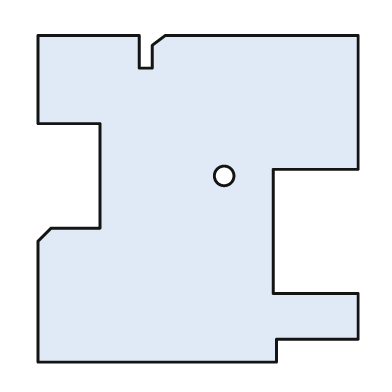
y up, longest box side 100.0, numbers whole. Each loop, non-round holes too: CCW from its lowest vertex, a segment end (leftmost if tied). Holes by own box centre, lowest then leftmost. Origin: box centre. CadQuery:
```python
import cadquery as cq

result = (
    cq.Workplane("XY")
    .moveTo(-49.0, -50.0)
    .lineTo(24.0, -50.0)
    .lineTo(24.0, -43.0)
    .lineTo(49.0, -43.0)
    .lineTo(49.0, -29.0)
    .lineTo(23.0, -29.0)
    .lineTo(23.0, 9.0)
    .lineTo(49.0, 9.0)
    .lineTo(49.0, 50.0)
    .lineTo(-10.0, 50.0)
    .lineTo(-14.0, 47.0)
    .lineTo(-14.0, 40.0)
    .lineTo(-18.0, 40.0)
    .lineTo(-18.0, 50.0)
    .lineTo(-49.0, 50.0)
    .lineTo(-49.0, 23.0)
    .lineTo(-30.0, 23.0)
    .lineTo(-30.0, -9.0)
    .lineTo(-45.0, -9.0)
    .lineTo(-49.0, -13.0)
    .close()
    .moveTo(8.0, 7.0)
    .circle(3.0)
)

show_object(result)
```